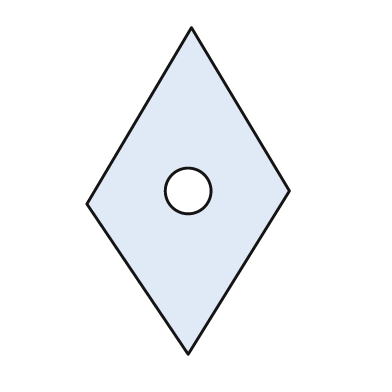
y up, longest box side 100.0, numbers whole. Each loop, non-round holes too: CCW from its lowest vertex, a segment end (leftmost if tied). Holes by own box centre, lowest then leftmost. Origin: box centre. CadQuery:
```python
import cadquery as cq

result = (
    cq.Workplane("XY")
    .moveTo(0.0, -50.0)
    .lineTo(31.0, 0.0)
    .lineTo(1.0, 50.0)
    .lineTo(-31.0, -4.0)
    .close()
    .moveTo(0.0, 0.0)
    .circle(7.0)
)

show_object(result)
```